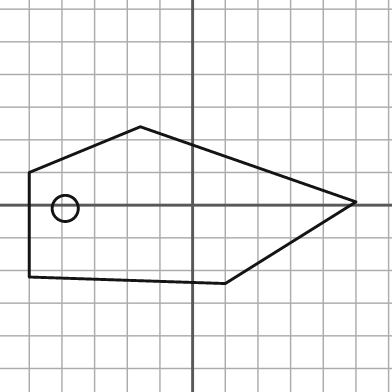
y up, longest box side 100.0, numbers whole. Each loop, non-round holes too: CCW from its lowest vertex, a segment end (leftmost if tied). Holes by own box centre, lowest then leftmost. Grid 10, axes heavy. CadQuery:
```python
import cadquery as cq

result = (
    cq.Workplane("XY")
    .moveTo(10.0, -24.0)
    .lineTo(50.0, 1.0)
    .lineTo(-16.0, 24.0)
    .lineTo(-50.0, 10.0)
    .lineTo(-50.0, -22.0)
    .close()
    .moveTo(-39.0, -1.0)
    .circle(4.0)
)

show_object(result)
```